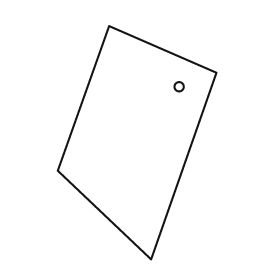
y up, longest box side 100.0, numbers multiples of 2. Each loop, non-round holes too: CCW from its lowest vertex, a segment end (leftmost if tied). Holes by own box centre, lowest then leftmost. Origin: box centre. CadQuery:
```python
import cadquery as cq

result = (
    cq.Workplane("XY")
    .moveTo(6.0, -50.0)
    .lineTo(34.0, 30.0)
    .lineTo(-12.0, 50.0)
    .lineTo(-34.0, -12.0)
    .close()
    .moveTo(18.0, 24.0)
    .circle(2.0)
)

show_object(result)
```